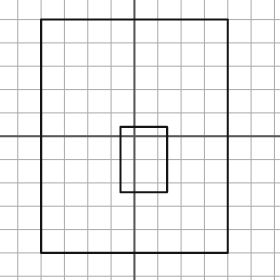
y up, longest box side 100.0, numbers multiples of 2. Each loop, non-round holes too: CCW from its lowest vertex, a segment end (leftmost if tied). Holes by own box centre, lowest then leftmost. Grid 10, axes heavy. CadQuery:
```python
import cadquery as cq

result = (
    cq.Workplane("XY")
    .moveTo(-40.0, -50.0)
    .lineTo(40.0, -50.0)
    .lineTo(40.0, 50.0)
    .lineTo(-40.0, 50.0)
    .close()
    .moveTo(-6.0, -24.0)
    .lineTo(14.0, -24.0)
    .lineTo(14.0, 4.0)
    .lineTo(-6.0, 4.0)
    .close()
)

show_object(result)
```